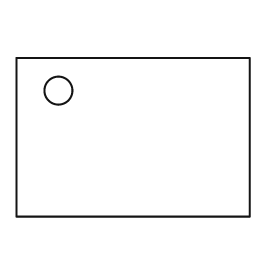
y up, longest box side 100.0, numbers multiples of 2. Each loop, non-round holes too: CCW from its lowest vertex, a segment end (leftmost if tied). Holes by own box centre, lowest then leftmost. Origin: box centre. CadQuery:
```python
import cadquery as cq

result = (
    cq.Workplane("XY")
    .moveTo(-50.0, -34.0)
    .lineTo(50.0, -34.0)
    .lineTo(50.0, 34.0)
    .lineTo(-50.0, 34.0)
    .close()
    .moveTo(-32.0, 20.0)
    .circle(6.0)
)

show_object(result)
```